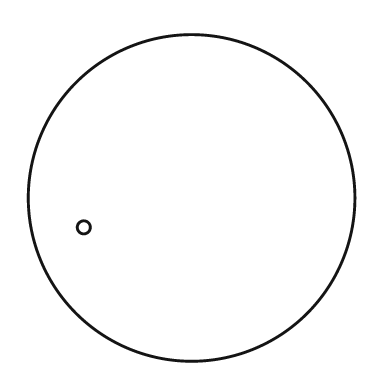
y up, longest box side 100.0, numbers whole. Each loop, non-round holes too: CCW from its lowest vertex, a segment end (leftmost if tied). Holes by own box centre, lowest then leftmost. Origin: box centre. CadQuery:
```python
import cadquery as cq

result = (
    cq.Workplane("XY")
    .moveTo(0.0, 0.0)
    .circle(50.0)
    .moveTo(-33.0, -9.0)
    .circle(2.0)
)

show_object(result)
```